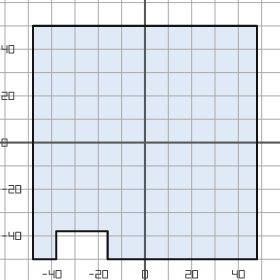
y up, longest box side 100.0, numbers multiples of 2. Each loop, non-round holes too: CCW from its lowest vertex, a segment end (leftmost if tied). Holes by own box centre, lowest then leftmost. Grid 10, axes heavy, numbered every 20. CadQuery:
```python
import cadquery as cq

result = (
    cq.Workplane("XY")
    .moveTo(-48.0, -50.0)
    .lineTo(-38.0, -50.0)
    .lineTo(-38.0, -38.0)
    .lineTo(-16.0, -38.0)
    .lineTo(-16.0, -50.0)
    .lineTo(48.0, -50.0)
    .lineTo(48.0, 50.0)
    .lineTo(-48.0, 50.0)
    .close()
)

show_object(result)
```